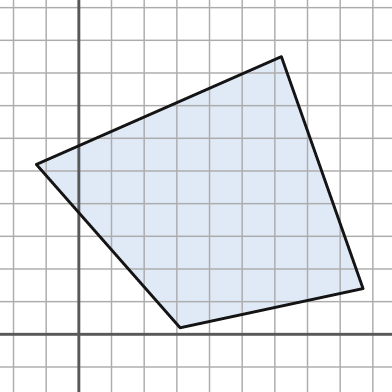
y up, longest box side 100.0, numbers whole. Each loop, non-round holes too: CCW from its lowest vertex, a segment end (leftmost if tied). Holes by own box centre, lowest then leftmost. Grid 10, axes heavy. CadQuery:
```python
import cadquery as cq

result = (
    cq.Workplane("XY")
    .moveTo(31.0, 2.0)
    .lineTo(87.0, 14.0)
    .lineTo(62.0, 85.0)
    .lineTo(-13.0, 52.0)
    .close()
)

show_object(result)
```